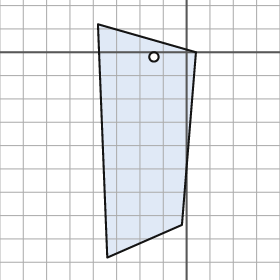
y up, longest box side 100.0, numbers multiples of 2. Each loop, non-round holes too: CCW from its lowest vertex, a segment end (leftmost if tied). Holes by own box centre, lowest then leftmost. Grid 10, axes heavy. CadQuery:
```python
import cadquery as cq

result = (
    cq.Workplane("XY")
    .moveTo(-34.0, -88.0)
    .lineTo(-2.0, -74.0)
    .lineTo(4.0, 0.0)
    .lineTo(-38.0, 12.0)
    .close()
    .moveTo(-14.0, -2.0)
    .circle(2.0)
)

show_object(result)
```